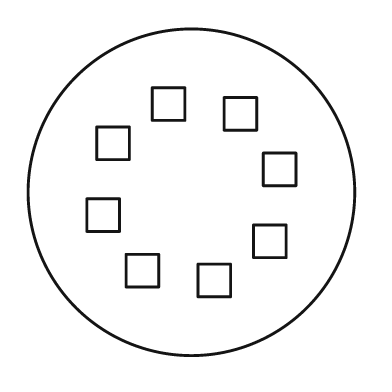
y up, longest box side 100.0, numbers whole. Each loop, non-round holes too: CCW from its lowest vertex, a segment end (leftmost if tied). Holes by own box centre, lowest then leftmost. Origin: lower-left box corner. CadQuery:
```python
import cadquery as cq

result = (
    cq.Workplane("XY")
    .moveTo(50.0, 50.0)
    .circle(50.0)
    .moveTo(52.0, 18.0)
    .lineTo(62.0, 18.0)
    .lineTo(62.0, 28.0)
    .lineTo(52.0, 28.0)
    .close()
    .moveTo(30.0, 21.0)
    .lineTo(40.0, 21.0)
    .lineTo(40.0, 31.0)
    .lineTo(30.0, 31.0)
    .close()
    .moveTo(69.0, 30.0)
    .lineTo(79.0, 30.0)
    .lineTo(79.0, 40.0)
    .lineTo(69.0, 40.0)
    .close()
    .moveTo(18.0, 38.0)
    .lineTo(28.0, 38.0)
    .lineTo(28.0, 48.0)
    .lineTo(18.0, 48.0)
    .close()
    .moveTo(72.0, 52.0)
    .lineTo(82.0, 52.0)
    .lineTo(82.0, 62.0)
    .lineTo(72.0, 62.0)
    .close()
    .moveTo(21.0, 60.0)
    .lineTo(31.0, 60.0)
    .lineTo(31.0, 70.0)
    .lineTo(21.0, 70.0)
    .close()
    .moveTo(60.0, 69.0)
    .lineTo(70.0, 69.0)
    .lineTo(70.0, 79.0)
    .lineTo(60.0, 79.0)
    .close()
    .moveTo(38.0, 72.0)
    .lineTo(48.0, 72.0)
    .lineTo(48.0, 82.0)
    .lineTo(38.0, 82.0)
    .close()
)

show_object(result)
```